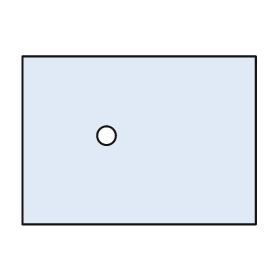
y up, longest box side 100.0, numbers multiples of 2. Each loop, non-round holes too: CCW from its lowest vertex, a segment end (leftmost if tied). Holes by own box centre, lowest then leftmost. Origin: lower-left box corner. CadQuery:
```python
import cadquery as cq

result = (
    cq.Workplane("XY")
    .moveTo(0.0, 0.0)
    .lineTo(100.0, 0.0)
    .lineTo(100.0, 72.0)
    .lineTo(0.0, 72.0)
    .close()
    .moveTo(36.0, 38.0)
    .circle(4.0)
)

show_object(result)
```